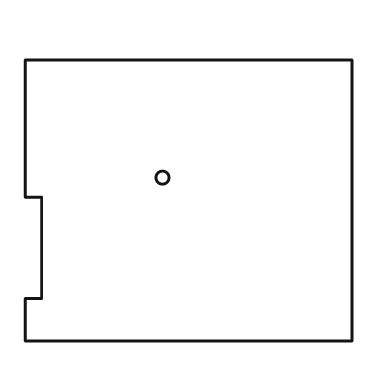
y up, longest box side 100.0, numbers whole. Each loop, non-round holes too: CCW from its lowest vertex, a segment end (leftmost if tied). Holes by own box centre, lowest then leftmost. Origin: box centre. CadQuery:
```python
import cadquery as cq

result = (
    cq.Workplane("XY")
    .moveTo(-50.0, -43.0)
    .lineTo(50.0, -43.0)
    .lineTo(50.0, 43.0)
    .lineTo(-50.0, 43.0)
    .lineTo(-50.0, 1.0)
    .lineTo(-45.0, 1.0)
    .lineTo(-45.0, -30.0)
    .lineTo(-50.0, -30.0)
    .close()
    .moveTo(-8.0, 7.0)
    .circle(2.0)
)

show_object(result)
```